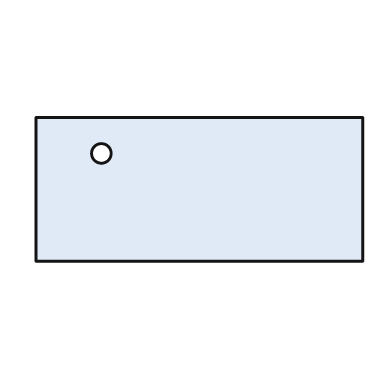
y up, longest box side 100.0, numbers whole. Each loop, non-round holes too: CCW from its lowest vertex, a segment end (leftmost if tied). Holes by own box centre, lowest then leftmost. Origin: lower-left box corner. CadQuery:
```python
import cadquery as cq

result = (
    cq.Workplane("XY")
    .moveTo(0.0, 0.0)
    .lineTo(100.0, 0.0)
    .lineTo(100.0, 44.0)
    .lineTo(0.0, 44.0)
    .close()
    .moveTo(20.0, 33.0)
    .circle(3.0)
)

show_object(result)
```